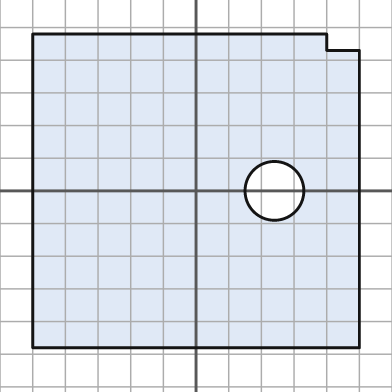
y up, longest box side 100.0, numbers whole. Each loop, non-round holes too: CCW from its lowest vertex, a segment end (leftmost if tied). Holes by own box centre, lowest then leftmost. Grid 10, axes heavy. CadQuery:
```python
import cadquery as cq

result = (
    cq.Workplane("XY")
    .moveTo(-50.0, -48.0)
    .lineTo(50.0, -48.0)
    .lineTo(50.0, 43.0)
    .lineTo(40.0, 43.0)
    .lineTo(40.0, 48.0)
    .lineTo(-50.0, 48.0)
    .close()
    .moveTo(24.0, 0.0)
    .circle(9.0)
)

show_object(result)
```